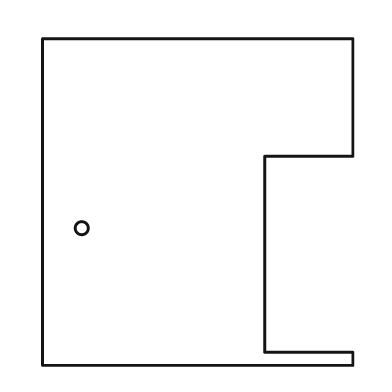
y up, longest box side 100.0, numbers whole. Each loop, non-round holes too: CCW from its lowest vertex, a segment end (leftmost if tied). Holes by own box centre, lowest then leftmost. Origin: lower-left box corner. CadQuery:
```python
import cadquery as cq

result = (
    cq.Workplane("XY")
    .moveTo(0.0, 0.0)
    .lineTo(95.0, 0.0)
    .lineTo(95.0, 4.0)
    .lineTo(68.0, 4.0)
    .lineTo(68.0, 64.0)
    .lineTo(95.0, 64.0)
    .lineTo(95.0, 100.0)
    .lineTo(0.0, 100.0)
    .close()
    .moveTo(12.0, 42.0)
    .circle(2.0)
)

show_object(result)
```